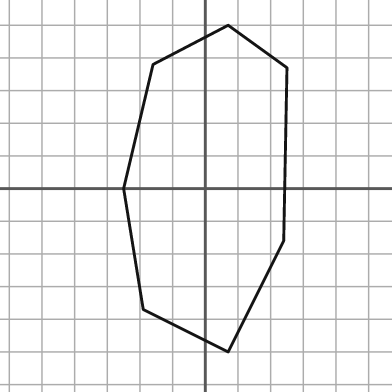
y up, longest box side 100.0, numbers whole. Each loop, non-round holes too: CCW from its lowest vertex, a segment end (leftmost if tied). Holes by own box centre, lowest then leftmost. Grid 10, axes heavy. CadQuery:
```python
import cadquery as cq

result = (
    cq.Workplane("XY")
    .moveTo(7.0, -50.0)
    .lineTo(24.0, -16.0)
    .lineTo(25.0, 37.0)
    .lineTo(7.0, 50.0)
    .lineTo(-16.0, 38.0)
    .lineTo(-25.0, 0.0)
    .lineTo(-19.0, -37.0)
    .close()
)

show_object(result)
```